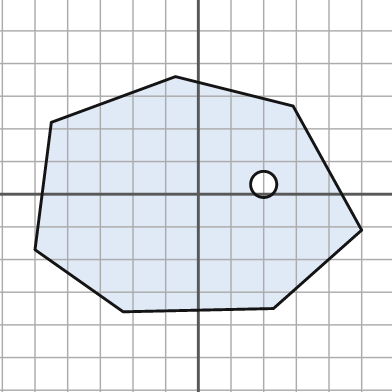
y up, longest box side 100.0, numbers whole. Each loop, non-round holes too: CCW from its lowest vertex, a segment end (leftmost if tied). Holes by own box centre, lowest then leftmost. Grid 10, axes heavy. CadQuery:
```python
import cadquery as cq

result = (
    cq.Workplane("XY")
    .moveTo(-23.0, -36.0)
    .lineTo(23.0, -35.0)
    .lineTo(50.0, -11.0)
    .lineTo(29.0, 27.0)
    .lineTo(-7.0, 36.0)
    .lineTo(-45.0, 22.0)
    .lineTo(-50.0, -17.0)
    .close()
    .moveTo(20.0, 3.0)
    .circle(4.0)
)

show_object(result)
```